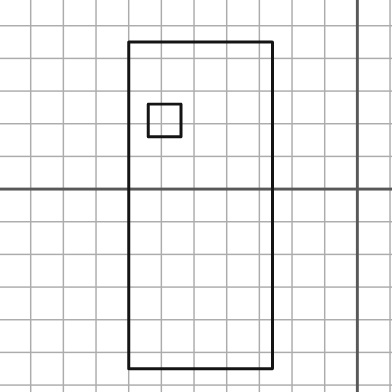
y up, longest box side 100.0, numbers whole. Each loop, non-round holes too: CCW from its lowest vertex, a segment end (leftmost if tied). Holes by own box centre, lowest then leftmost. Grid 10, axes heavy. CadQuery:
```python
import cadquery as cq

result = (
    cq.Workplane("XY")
    .moveTo(-70.0, -55.0)
    .lineTo(-26.0, -55.0)
    .lineTo(-26.0, 45.0)
    .lineTo(-70.0, 45.0)
    .close()
    .moveTo(-64.0, 16.0)
    .lineTo(-54.0, 16.0)
    .lineTo(-54.0, 26.0)
    .lineTo(-64.0, 26.0)
    .close()
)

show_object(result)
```